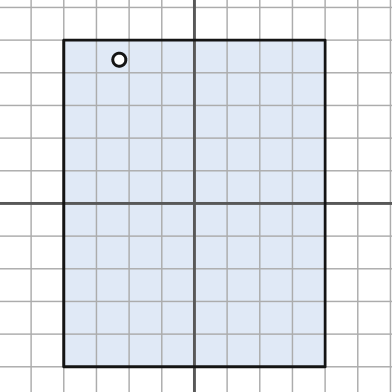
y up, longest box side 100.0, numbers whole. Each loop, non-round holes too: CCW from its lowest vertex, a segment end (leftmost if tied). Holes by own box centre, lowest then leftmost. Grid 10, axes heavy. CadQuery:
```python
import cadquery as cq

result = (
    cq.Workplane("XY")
    .moveTo(-40.0, -50.0)
    .lineTo(40.0, -50.0)
    .lineTo(40.0, 50.0)
    .lineTo(-40.0, 50.0)
    .close()
    .moveTo(-23.0, 44.0)
    .circle(2.0)
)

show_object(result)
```